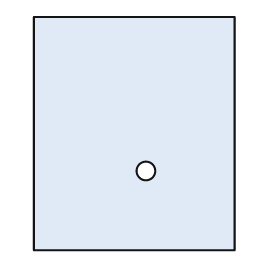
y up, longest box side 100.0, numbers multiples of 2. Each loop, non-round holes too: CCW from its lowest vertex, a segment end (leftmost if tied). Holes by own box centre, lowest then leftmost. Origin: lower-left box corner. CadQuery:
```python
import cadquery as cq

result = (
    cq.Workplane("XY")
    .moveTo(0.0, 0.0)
    .lineTo(86.0, 0.0)
    .lineTo(86.0, 100.0)
    .lineTo(0.0, 100.0)
    .close()
    .moveTo(48.0, 34.0)
    .circle(4.0)
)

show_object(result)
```